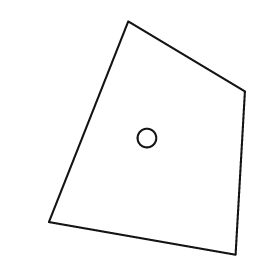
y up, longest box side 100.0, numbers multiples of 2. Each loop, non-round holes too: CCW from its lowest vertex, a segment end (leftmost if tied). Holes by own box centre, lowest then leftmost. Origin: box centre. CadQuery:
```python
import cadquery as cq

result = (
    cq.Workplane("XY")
    .moveTo(38.0, -50.0)
    .lineTo(42.0, 20.0)
    .lineTo(-8.0, 50.0)
    .lineTo(-42.0, -36.0)
    .close()
    .moveTo(0.0, 0.0)
    .circle(4.0)
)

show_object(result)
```